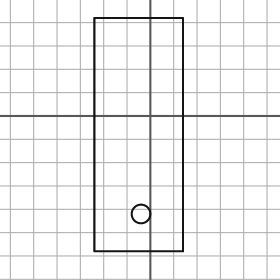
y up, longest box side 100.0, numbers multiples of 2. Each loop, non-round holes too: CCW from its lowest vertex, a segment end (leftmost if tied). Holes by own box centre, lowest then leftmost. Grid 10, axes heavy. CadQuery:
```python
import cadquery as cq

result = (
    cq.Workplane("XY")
    .moveTo(-24.0, -58.0)
    .lineTo(14.0, -58.0)
    .lineTo(14.0, 42.0)
    .lineTo(-24.0, 42.0)
    .close()
    .moveTo(-4.0, -42.0)
    .circle(4.0)
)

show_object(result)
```